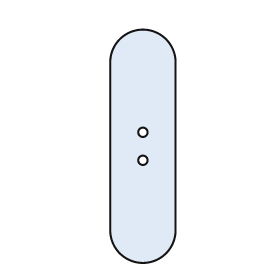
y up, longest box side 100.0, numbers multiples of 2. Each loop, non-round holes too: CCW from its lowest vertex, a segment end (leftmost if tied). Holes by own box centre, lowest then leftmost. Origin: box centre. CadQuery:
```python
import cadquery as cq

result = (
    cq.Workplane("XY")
    .moveTo(-14.0, -36.0)
    .threePointArc((0.0, -50.0), (14.0, -36.0))
    .lineTo(14.0, 36.0)
    .threePointArc((0.0, 50.0), (-14.0, 36.0))
    .close()
    .moveTo(0.0, -6.0)
    .circle(2.0)
    .moveTo(0.0, 6.0)
    .circle(2.0)
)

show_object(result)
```